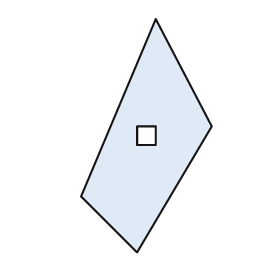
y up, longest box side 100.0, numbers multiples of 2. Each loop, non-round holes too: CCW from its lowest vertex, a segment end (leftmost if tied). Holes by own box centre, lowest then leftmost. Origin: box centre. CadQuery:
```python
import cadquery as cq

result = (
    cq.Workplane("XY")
    .moveTo(-4.0, -50.0)
    .lineTo(28.0, 4.0)
    .lineTo(4.0, 50.0)
    .lineTo(-28.0, -26.0)
    .close()
    .moveTo(-4.0, -4.0)
    .lineTo(4.0, -4.0)
    .lineTo(4.0, 4.0)
    .lineTo(-4.0, 4.0)
    .close()
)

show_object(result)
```